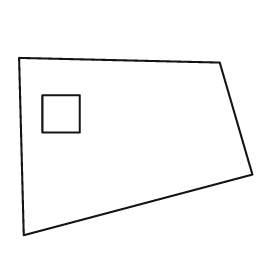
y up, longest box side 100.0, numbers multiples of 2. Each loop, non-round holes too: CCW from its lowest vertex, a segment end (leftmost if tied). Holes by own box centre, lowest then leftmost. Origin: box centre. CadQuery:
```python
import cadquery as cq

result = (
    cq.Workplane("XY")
    .moveTo(-48.0, -38.0)
    .lineTo(50.0, -12.0)
    .lineTo(36.0, 36.0)
    .lineTo(-50.0, 38.0)
    .close()
    .moveTo(-40.0, 6.0)
    .lineTo(-24.0, 6.0)
    .lineTo(-24.0, 22.0)
    .lineTo(-40.0, 22.0)
    .close()
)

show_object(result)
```